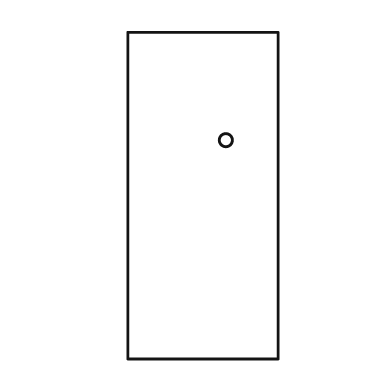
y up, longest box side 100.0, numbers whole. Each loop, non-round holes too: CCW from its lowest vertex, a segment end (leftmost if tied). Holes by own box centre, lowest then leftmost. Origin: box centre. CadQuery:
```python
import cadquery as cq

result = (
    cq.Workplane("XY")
    .moveTo(-23.0, -50.0)
    .lineTo(23.0, -50.0)
    .lineTo(23.0, 50.0)
    .lineTo(-23.0, 50.0)
    .close()
    .moveTo(7.0, 17.0)
    .circle(2.0)
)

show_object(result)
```